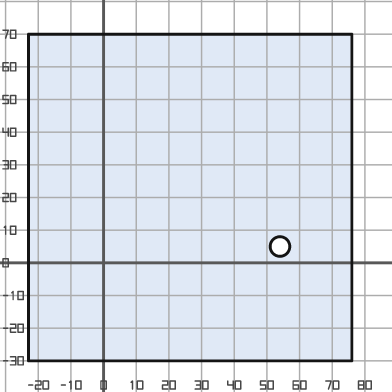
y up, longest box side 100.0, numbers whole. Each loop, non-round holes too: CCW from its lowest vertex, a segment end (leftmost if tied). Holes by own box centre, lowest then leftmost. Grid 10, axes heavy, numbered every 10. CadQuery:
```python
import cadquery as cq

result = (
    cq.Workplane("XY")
    .moveTo(-23.0, -30.0)
    .lineTo(76.0, -30.0)
    .lineTo(76.0, 70.0)
    .lineTo(-23.0, 70.0)
    .close()
    .moveTo(54.0, 5.0)
    .circle(3.0)
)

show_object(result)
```